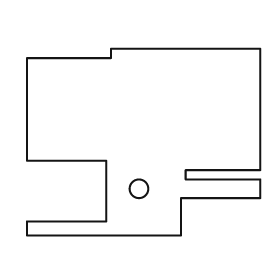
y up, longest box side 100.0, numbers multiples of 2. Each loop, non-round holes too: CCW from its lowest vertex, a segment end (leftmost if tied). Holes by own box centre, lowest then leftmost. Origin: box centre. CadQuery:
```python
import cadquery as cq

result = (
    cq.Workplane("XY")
    .moveTo(-50.0, -40.0)
    .lineTo(16.0, -40.0)
    .lineTo(16.0, -24.0)
    .lineTo(50.0, -24.0)
    .lineTo(50.0, -16.0)
    .lineTo(18.0, -16.0)
    .lineTo(18.0, -12.0)
    .lineTo(50.0, -12.0)
    .lineTo(50.0, 40.0)
    .lineTo(-14.0, 40.0)
    .lineTo(-14.0, 36.0)
    .lineTo(-50.0, 36.0)
    .lineTo(-50.0, -8.0)
    .lineTo(-16.0, -8.0)
    .lineTo(-16.0, -34.0)
    .lineTo(-50.0, -34.0)
    .close()
    .moveTo(-2.0, -20.0)
    .circle(4.0)
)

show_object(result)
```